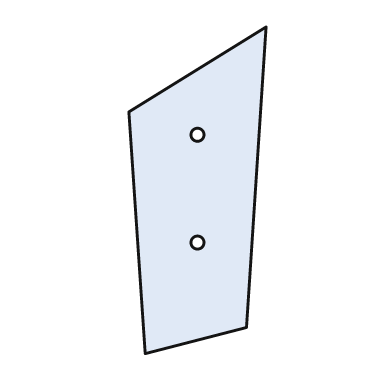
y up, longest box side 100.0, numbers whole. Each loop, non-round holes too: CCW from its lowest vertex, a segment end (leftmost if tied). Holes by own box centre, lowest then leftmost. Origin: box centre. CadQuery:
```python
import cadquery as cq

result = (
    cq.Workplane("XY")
    .moveTo(-16.0, -50.0)
    .lineTo(15.0, -42.0)
    .lineTo(21.0, 50.0)
    .lineTo(-21.0, 24.0)
    .close()
    .moveTo(0.0, -16.0)
    .circle(2.0)
    .moveTo(0.0, 17.0)
    .circle(2.0)
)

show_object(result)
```